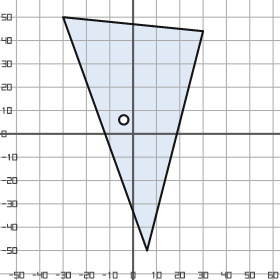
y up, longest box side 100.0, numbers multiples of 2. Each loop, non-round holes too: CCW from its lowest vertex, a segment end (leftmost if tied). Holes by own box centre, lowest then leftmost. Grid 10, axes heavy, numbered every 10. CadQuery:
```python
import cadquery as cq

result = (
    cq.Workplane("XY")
    .moveTo(6.0, -50.0)
    .lineTo(30.0, 44.0)
    .lineTo(-30.0, 50.0)
    .close()
    .moveTo(-4.0, 6.0)
    .circle(2.0)
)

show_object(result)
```